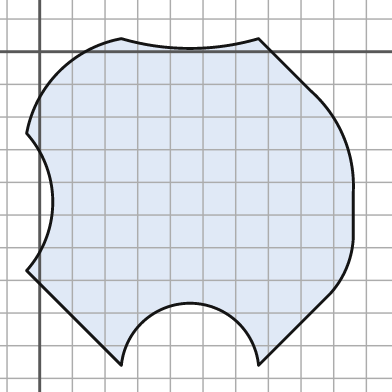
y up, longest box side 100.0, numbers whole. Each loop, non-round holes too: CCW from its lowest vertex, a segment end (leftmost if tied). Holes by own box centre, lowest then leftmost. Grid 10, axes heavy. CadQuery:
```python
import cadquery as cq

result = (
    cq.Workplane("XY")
    .moveTo(25.0, -96.0)
    .threePointArc((46.0, -77.0), (67.0, -96.0))
    .lineTo(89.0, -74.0)
    .threePointArc((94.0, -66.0), (96.0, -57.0))
    .lineTo(96.0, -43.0)
    .threePointArc((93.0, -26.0), (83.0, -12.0))
    .lineTo(67.0, 4.0)
    .threePointArc((46.0, 1.0), (25.0, 4.0))
    .threePointArc((6.0, -6.0), (-4.0, -25.0))
    .threePointArc((4.0, -46.0), (-4.0, -67.0))
    .close()
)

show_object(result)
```